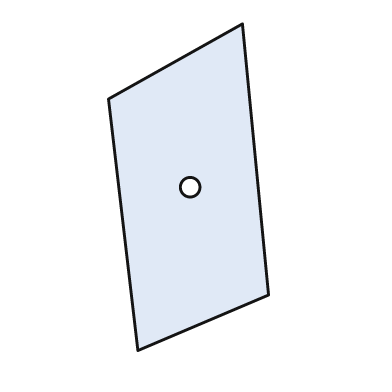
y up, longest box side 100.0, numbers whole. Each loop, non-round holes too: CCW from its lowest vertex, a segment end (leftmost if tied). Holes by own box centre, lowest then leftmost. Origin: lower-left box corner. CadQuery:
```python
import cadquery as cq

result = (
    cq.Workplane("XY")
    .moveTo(9.0, 0.0)
    .lineTo(49.0, 17.0)
    .lineTo(41.0, 100.0)
    .lineTo(0.0, 77.0)
    .close()
    .moveTo(25.0, 50.0)
    .circle(3.0)
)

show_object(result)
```